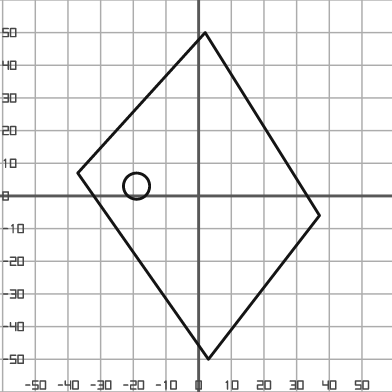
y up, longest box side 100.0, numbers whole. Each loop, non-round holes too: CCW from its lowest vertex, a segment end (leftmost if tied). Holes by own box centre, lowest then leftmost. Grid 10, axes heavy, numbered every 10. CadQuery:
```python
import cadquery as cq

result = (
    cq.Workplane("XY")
    .moveTo(3.0, -50.0)
    .lineTo(37.0, -6.0)
    .lineTo(2.0, 50.0)
    .lineTo(-37.0, 7.0)
    .close()
    .moveTo(-19.0, 3.0)
    .circle(4.0)
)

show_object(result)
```